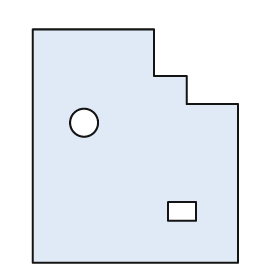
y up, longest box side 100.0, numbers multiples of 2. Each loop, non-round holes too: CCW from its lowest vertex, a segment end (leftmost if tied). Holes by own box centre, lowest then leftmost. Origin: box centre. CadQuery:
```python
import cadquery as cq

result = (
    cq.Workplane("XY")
    .moveTo(-44.0, -50.0)
    .lineTo(44.0, -50.0)
    .lineTo(44.0, 18.0)
    .lineTo(22.0, 18.0)
    .lineTo(22.0, 30.0)
    .lineTo(8.0, 30.0)
    .lineTo(8.0, 50.0)
    .lineTo(-44.0, 50.0)
    .close()
    .moveTo(14.0, -32.0)
    .lineTo(26.0, -32.0)
    .lineTo(26.0, -24.0)
    .lineTo(14.0, -24.0)
    .close()
    .moveTo(-22.0, 10.0)
    .circle(6.0)
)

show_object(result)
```